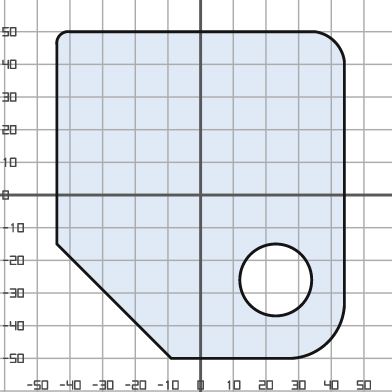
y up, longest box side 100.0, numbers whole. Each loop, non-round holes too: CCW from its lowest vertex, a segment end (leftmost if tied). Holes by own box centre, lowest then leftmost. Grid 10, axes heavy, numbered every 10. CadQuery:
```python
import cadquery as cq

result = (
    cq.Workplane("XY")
    .moveTo(-9.0, -50.0)
    .lineTo(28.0, -50.0)
    .threePointArc((39.0, -45.0), (44.0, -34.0))
    .lineTo(44.0, 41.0)
    .threePointArc((41.0, 47.0), (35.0, 50.0))
    .lineTo(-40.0, 50.0)
    .threePointArc((-43.0, 49.0), (-44.0, 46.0))
    .lineTo(-44.0, -15.0)
    .close()
    .moveTo(23.0, -26.0)
    .circle(11.0)
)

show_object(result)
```